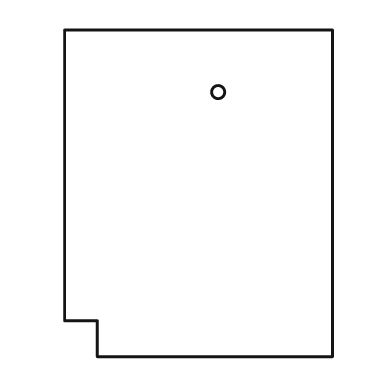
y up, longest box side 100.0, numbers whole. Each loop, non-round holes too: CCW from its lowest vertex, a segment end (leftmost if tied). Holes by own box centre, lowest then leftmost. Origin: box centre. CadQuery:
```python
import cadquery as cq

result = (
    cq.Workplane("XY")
    .moveTo(-31.0, -50.0)
    .lineTo(41.0, -50.0)
    .lineTo(41.0, 50.0)
    .lineTo(-41.0, 50.0)
    .lineTo(-41.0, -39.0)
    .lineTo(-31.0, -39.0)
    .close()
    .moveTo(6.0, 31.0)
    .circle(2.0)
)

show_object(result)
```